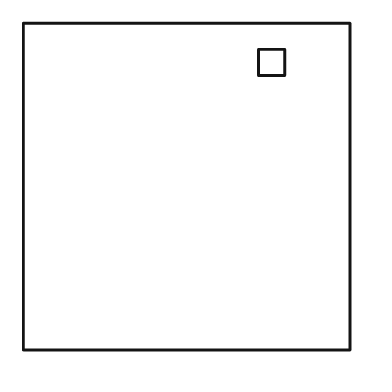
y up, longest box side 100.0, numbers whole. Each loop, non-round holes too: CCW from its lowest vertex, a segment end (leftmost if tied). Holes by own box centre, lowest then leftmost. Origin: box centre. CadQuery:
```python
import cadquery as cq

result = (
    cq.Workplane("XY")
    .moveTo(-50.0, -50.0)
    .lineTo(50.0, -50.0)
    .lineTo(50.0, 50.0)
    .lineTo(-50.0, 50.0)
    .close()
    .moveTo(22.0, 34.0)
    .lineTo(30.0, 34.0)
    .lineTo(30.0, 42.0)
    .lineTo(22.0, 42.0)
    .close()
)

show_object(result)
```